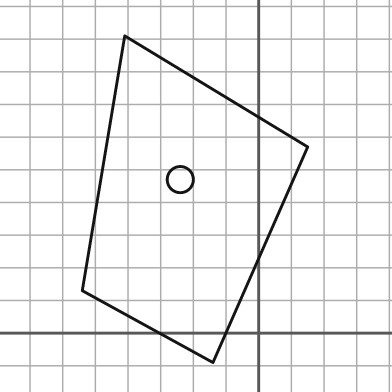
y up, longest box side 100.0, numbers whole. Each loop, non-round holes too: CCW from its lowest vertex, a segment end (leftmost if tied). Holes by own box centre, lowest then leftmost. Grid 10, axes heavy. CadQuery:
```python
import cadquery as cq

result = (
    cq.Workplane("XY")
    .moveTo(-14.0, -9.0)
    .lineTo(15.0, 57.0)
    .lineTo(-41.0, 91.0)
    .lineTo(-54.0, 13.0)
    .close()
    .moveTo(-24.0, 47.0)
    .circle(4.0)
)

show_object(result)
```